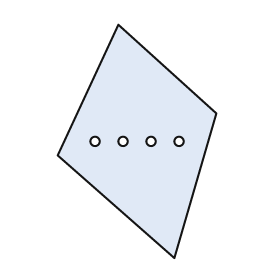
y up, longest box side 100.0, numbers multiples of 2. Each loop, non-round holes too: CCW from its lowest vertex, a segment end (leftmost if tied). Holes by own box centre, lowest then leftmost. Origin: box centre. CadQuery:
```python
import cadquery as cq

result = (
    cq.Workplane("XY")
    .moveTo(16.0, -50.0)
    .lineTo(34.0, 12.0)
    .lineTo(-8.0, 50.0)
    .lineTo(-34.0, -6.0)
    .close()
    .moveTo(-18.0, 0.0)
    .circle(2.0)
    .moveTo(-6.0, 0.0)
    .circle(2.0)
    .moveTo(6.0, 0.0)
    .circle(2.0)
    .moveTo(18.0, 0.0)
    .circle(2.0)
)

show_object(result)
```